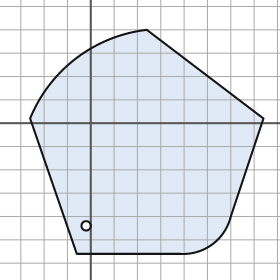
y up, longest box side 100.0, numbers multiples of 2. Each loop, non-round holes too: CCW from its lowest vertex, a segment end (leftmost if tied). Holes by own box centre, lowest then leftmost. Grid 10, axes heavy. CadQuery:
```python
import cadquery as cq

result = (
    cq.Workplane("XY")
    .moveTo(-6.0, -56.0)
    .lineTo(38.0, -56.0)
    .threePointArc((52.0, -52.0), (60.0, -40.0))
    .lineTo(74.0, 2.0)
    .lineTo(24.0, 40.0)
    .threePointArc((-6.0, 28.0), (-26.0, 2.0))
    .close()
    .moveTo(-2.0, -44.0)
    .circle(2.0)
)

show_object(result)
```